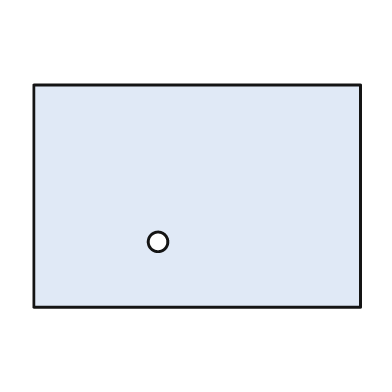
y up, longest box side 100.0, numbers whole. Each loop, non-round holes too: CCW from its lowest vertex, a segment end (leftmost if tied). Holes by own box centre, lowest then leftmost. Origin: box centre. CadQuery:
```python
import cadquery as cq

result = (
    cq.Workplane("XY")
    .moveTo(-50.0, -34.0)
    .lineTo(50.0, -34.0)
    .lineTo(50.0, 34.0)
    .lineTo(-50.0, 34.0)
    .close()
    .moveTo(-12.0, -14.0)
    .circle(3.0)
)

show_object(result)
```